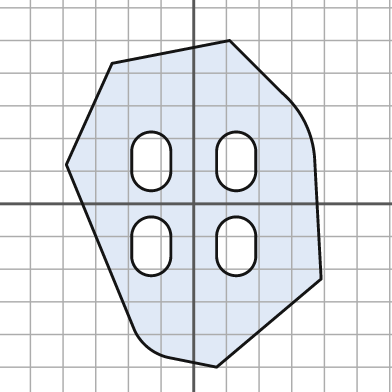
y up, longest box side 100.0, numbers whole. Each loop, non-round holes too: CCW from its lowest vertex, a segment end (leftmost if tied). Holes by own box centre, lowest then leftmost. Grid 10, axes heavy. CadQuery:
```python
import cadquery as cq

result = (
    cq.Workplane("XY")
    .moveTo(7.0, -50.0)
    .lineTo(39.0, -23.0)
    .lineTo(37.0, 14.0)
    .threePointArc((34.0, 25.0), (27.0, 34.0))
    .lineTo(11.0, 50.0)
    .lineTo(-25.0, 43.0)
    .lineTo(-39.0, 12.0)
    .lineTo(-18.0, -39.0)
    .threePointArc((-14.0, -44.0), (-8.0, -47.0))
    .close()
    .moveTo(-19.0, -16.0)
    .threePointArc((-13.0, -22.0), (-7.0, -16.0))
    .lineTo(-7.0, -10.0)
    .threePointArc((-13.0, -4.0), (-19.0, -10.0))
    .close()
    .moveTo(7.0, -16.0)
    .threePointArc((13.0, -22.0), (19.0, -16.0))
    .lineTo(19.0, -10.0)
    .threePointArc((13.0, -4.0), (7.0, -10.0))
    .close()
    .moveTo(-19.0, 10.0)
    .threePointArc((-13.0, 4.0), (-7.0, 10.0))
    .lineTo(-7.0, 16.0)
    .threePointArc((-13.0, 22.0), (-19.0, 16.0))
    .close()
    .moveTo(7.0, 10.0)
    .threePointArc((13.0, 4.0), (19.0, 10.0))
    .lineTo(19.0, 16.0)
    .threePointArc((13.0, 22.0), (7.0, 16.0))
    .close()
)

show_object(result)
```